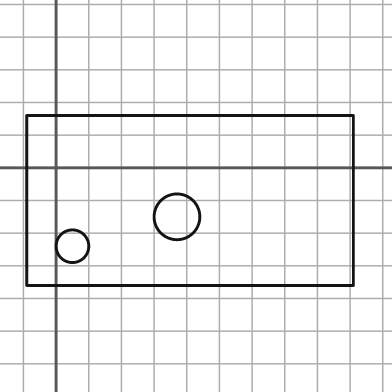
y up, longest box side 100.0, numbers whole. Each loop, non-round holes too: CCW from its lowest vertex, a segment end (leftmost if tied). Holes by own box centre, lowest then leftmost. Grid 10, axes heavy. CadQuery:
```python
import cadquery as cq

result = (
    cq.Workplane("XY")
    .moveTo(-9.0, -36.0)
    .lineTo(91.0, -36.0)
    .lineTo(91.0, 16.0)
    .lineTo(-9.0, 16.0)
    .close()
    .moveTo(5.0, -24.0)
    .circle(5.0)
    .moveTo(37.0, -15.0)
    .circle(7.0)
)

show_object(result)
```